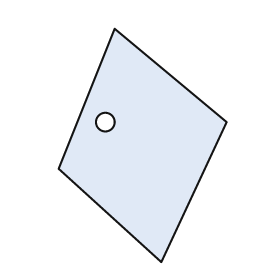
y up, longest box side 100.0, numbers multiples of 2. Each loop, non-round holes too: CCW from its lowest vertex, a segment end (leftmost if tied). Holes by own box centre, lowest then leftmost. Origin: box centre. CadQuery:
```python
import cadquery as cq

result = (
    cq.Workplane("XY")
    .moveTo(8.0, -50.0)
    .lineTo(36.0, 10.0)
    .lineTo(-12.0, 50.0)
    .lineTo(-36.0, -10.0)
    .close()
    .moveTo(-16.0, 10.0)
    .circle(4.0)
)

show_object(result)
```